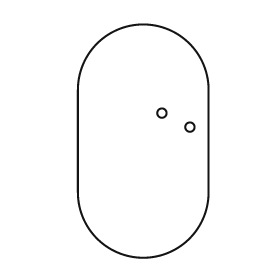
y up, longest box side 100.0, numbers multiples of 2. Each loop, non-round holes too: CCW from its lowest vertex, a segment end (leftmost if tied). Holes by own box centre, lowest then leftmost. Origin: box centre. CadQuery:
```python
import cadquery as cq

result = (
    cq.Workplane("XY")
    .moveTo(-28.0, -22.0)
    .threePointArc((0.0, -50.0), (28.0, -22.0))
    .lineTo(28.0, 22.0)
    .threePointArc((0.0, 50.0), (-28.0, 22.0))
    .close()
    .moveTo(20.0, 6.0)
    .circle(2.0)
    .moveTo(8.0, 12.0)
    .circle(2.0)
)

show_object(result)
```